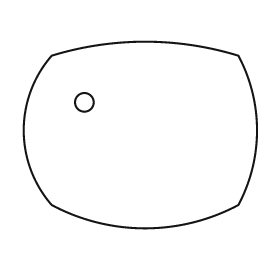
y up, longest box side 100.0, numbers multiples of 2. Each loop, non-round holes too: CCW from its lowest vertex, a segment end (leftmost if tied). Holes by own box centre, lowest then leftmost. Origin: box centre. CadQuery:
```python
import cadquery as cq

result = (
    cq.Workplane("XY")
    .moveTo(-38.0, -30.0)
    .threePointArc((2.0, -40.0), (42.0, -30.0))
    .threePointArc((50.0, 2.0), (42.0, 34.0))
    .threePointArc((2.0, 40.0), (-38.0, 34.0))
    .threePointArc((-50.0, 2.0), (-38.0, -30.0))
    .close()
    .moveTo(-24.0, 14.0)
    .circle(4.0)
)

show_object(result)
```